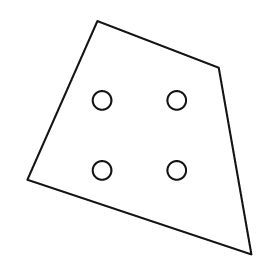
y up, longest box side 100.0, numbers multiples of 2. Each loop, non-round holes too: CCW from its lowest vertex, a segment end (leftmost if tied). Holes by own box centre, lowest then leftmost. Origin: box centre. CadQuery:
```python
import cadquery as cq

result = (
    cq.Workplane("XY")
    .moveTo(48.0, -50.0)
    .lineTo(34.0, 30.0)
    .lineTo(-18.0, 50.0)
    .lineTo(-48.0, -18.0)
    .close()
    .moveTo(-16.0, -14.0)
    .circle(4.0)
    .moveTo(16.0, -14.0)
    .circle(4.0)
    .moveTo(-16.0, 16.0)
    .circle(4.0)
    .moveTo(16.0, 16.0)
    .circle(4.0)
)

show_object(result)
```